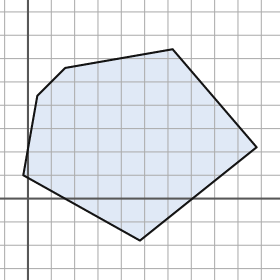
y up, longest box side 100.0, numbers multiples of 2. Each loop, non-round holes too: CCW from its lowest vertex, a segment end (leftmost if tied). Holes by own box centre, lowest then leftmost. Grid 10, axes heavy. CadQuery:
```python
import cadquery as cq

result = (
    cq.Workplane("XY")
    .moveTo(48.0, -18.0)
    .lineTo(98.0, 22.0)
    .lineTo(62.0, 64.0)
    .lineTo(16.0, 56.0)
    .lineTo(4.0, 44.0)
    .lineTo(-2.0, 10.0)
    .close()
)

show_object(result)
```